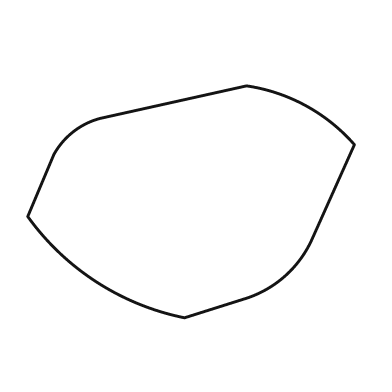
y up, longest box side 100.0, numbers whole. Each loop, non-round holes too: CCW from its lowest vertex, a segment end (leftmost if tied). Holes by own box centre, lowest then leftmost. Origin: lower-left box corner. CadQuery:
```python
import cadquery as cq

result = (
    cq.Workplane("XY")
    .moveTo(48.0, 0.0)
    .lineTo(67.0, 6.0)
    .threePointArc((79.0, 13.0), (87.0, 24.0))
    .lineTo(100.0, 53.0)
    .threePointArc((85.0, 65.0), (67.0, 71.0))
    .lineTo(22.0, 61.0)
    .threePointArc((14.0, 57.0), (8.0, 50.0))
    .lineTo(0.0, 31.0)
    .threePointArc((21.0, 11.0), (48.0, 0.0))
    .close()
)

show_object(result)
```